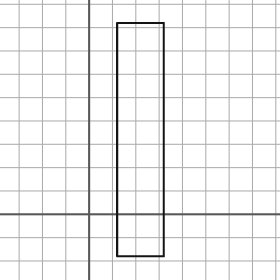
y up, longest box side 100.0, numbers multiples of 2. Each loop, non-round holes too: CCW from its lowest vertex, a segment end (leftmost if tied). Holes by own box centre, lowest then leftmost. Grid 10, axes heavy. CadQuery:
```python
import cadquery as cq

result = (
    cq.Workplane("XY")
    .moveTo(12.0, -18.0)
    .lineTo(32.0, -18.0)
    .lineTo(32.0, 82.0)
    .lineTo(12.0, 82.0)
    .close()
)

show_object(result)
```